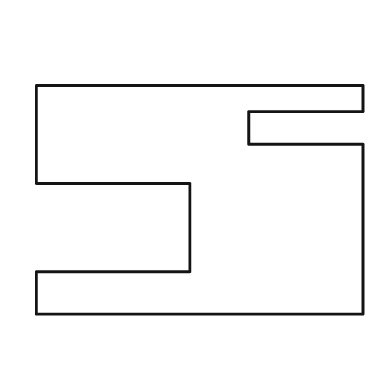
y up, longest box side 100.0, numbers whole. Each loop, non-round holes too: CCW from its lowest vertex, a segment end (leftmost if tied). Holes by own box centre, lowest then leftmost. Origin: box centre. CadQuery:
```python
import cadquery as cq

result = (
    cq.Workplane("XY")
    .moveTo(-50.0, -35.0)
    .lineTo(50.0, -35.0)
    .lineTo(50.0, 17.0)
    .lineTo(15.0, 17.0)
    .lineTo(15.0, 27.0)
    .lineTo(50.0, 27.0)
    .lineTo(50.0, 35.0)
    .lineTo(-50.0, 35.0)
    .lineTo(-50.0, 5.0)
    .lineTo(-3.0, 5.0)
    .lineTo(-3.0, -22.0)
    .lineTo(-50.0, -22.0)
    .close()
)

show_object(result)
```